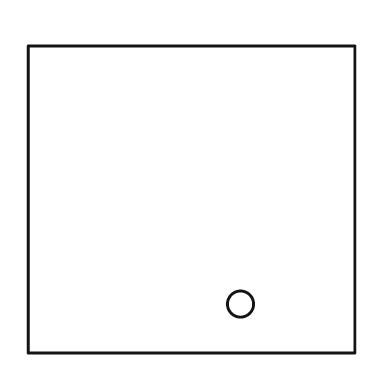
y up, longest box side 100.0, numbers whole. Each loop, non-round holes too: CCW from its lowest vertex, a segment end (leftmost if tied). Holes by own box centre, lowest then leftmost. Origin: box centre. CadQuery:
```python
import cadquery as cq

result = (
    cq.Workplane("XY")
    .moveTo(-50.0, -47.0)
    .lineTo(50.0, -47.0)
    .lineTo(50.0, 47.0)
    .lineTo(-50.0, 47.0)
    .close()
    .moveTo(15.0, -32.0)
    .circle(4.0)
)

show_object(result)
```